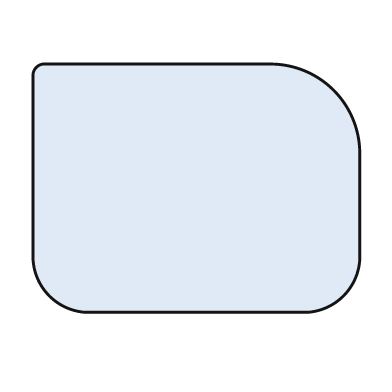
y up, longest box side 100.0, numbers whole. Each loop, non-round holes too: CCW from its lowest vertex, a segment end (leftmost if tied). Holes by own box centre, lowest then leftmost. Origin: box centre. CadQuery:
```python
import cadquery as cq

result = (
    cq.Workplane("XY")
    .moveTo(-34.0, -38.0)
    .lineTo(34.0, -38.0)
    .threePointArc((45.0, -33.0), (50.0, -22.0))
    .lineTo(50.0, 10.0)
    .threePointArc((42.0, 30.0), (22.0, 38.0))
    .lineTo(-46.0, 38.0)
    .threePointArc((-49.0, 37.0), (-50.0, 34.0))
    .lineTo(-50.0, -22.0)
    .threePointArc((-45.0, -33.0), (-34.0, -38.0))
    .close()
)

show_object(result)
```